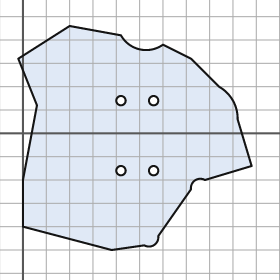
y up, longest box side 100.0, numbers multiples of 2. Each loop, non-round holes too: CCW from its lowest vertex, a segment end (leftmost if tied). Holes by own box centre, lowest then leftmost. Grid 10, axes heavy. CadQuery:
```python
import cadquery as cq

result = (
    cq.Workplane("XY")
    .moveTo(38.0, -50.0)
    .lineTo(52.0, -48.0)
    .threePointArc((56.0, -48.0), (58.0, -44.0))
    .lineTo(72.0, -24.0)
    .threePointArc((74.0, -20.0), (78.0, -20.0))
    .lineTo(98.0, -14.0)
    .lineTo(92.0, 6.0)
    .threePointArc((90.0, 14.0), (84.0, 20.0))
    .lineTo(72.0, 32.0)
    .lineTo(60.0, 38.0)
    .threePointArc((50.0, 36.0), (42.0, 42.0))
    .lineTo(20.0, 46.0)
    .lineTo(-2.0, 32.0)
    .lineTo(6.0, 12.0)
    .lineTo(0.0, -20.0)
    .lineTo(0.0, -40.0)
    .close()
    .moveTo(42.0, -16.0)
    .circle(2.0)
    .moveTo(56.0, -16.0)
    .circle(2.0)
    .moveTo(42.0, 14.0)
    .circle(2.0)
    .moveTo(56.0, 14.0)
    .circle(2.0)
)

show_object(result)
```